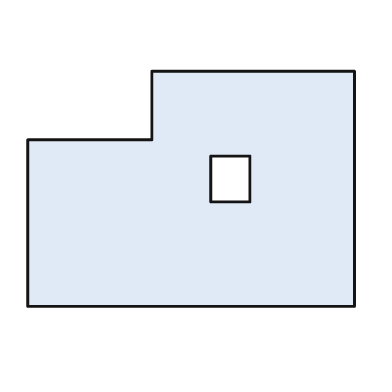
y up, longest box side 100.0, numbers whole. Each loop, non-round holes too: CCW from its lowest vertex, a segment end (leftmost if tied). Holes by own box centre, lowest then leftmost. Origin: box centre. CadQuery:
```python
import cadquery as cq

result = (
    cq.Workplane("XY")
    .moveTo(-50.0, -36.0)
    .lineTo(50.0, -36.0)
    .lineTo(50.0, 36.0)
    .lineTo(-12.0, 36.0)
    .lineTo(-12.0, 15.0)
    .lineTo(-50.0, 15.0)
    .close()
    .moveTo(6.0, -4.0)
    .lineTo(18.0, -4.0)
    .lineTo(18.0, 10.0)
    .lineTo(6.0, 10.0)
    .close()
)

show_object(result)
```